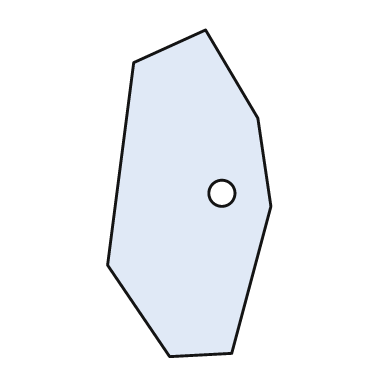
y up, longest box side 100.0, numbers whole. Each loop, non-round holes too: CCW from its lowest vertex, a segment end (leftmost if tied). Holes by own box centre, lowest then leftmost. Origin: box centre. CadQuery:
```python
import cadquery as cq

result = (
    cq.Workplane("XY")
    .moveTo(-6.0, -50.0)
    .lineTo(13.0, -49.0)
    .lineTo(25.0, -4.0)
    .lineTo(21.0, 23.0)
    .lineTo(5.0, 50.0)
    .lineTo(-17.0, 40.0)
    .lineTo(-25.0, -22.0)
    .close()
    .moveTo(10.0, 0.0)
    .circle(4.0)
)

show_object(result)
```